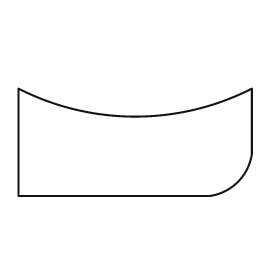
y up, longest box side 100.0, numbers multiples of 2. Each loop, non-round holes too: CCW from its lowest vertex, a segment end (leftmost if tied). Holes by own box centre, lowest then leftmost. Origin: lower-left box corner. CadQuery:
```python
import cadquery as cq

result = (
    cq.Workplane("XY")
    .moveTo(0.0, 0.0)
    .lineTo(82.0, 0.0)
    .threePointArc((94.0, 6.0), (100.0, 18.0))
    .lineTo(100.0, 46.0)
    .threePointArc((50.0, 34.0), (0.0, 46.0))
    .close()
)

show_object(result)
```